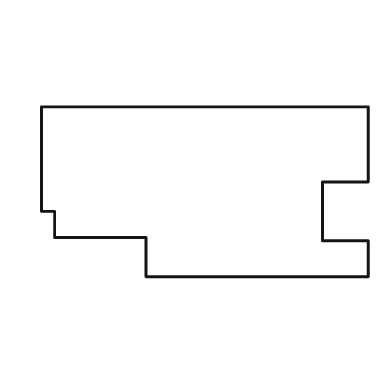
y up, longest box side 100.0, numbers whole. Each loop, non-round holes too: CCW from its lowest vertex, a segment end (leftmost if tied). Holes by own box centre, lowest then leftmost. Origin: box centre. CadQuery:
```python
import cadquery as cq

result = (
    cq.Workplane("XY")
    .moveTo(-18.0, -26.0)
    .lineTo(50.0, -26.0)
    .lineTo(50.0, -15.0)
    .lineTo(36.0, -15.0)
    .lineTo(36.0, 3.0)
    .lineTo(50.0, 3.0)
    .lineTo(50.0, 26.0)
    .lineTo(-50.0, 26.0)
    .lineTo(-50.0, -6.0)
    .lineTo(-46.0, -6.0)
    .lineTo(-46.0, -14.0)
    .lineTo(-18.0, -14.0)
    .close()
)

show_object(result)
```